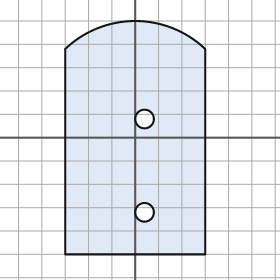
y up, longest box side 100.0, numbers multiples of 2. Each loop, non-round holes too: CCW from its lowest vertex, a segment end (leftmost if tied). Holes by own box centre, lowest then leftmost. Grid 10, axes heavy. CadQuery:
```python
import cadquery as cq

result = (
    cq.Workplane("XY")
    .moveTo(-30.0, -50.0)
    .lineTo(30.0, -50.0)
    .lineTo(30.0, 38.0)
    .threePointArc((0.0, 50.0), (-30.0, 38.0))
    .close()
    .moveTo(4.0, -32.0)
    .circle(4.0)
    .moveTo(4.0, 8.0)
    .circle(4.0)
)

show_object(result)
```